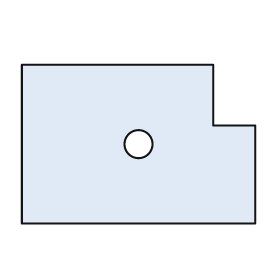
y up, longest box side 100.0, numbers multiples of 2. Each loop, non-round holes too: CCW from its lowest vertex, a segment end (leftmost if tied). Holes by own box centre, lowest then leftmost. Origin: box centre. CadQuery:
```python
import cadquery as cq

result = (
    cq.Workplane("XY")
    .moveTo(-50.0, -34.0)
    .lineTo(50.0, -34.0)
    .lineTo(50.0, 8.0)
    .lineTo(32.0, 8.0)
    .lineTo(32.0, 34.0)
    .lineTo(-50.0, 34.0)
    .close()
    .moveTo(0.0, 0.0)
    .circle(6.0)
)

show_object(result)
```